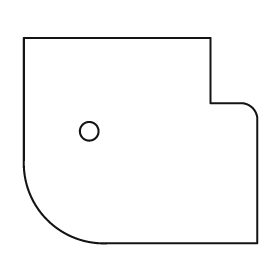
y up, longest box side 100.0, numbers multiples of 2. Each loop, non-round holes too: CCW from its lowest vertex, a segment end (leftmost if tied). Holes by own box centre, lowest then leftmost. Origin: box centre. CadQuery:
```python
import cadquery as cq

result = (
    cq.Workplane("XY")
    .moveTo(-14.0, -44.0)
    .lineTo(50.0, -44.0)
    .lineTo(50.0, 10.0)
    .threePointArc((48.0, 14.0), (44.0, 16.0))
    .lineTo(30.0, 16.0)
    .lineTo(30.0, 44.0)
    .lineTo(-50.0, 44.0)
    .lineTo(-50.0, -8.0)
    .threePointArc((-40.0, -34.0), (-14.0, -44.0))
    .close()
    .moveTo(-22.0, 4.0)
    .circle(4.0)
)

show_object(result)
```